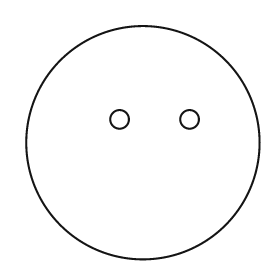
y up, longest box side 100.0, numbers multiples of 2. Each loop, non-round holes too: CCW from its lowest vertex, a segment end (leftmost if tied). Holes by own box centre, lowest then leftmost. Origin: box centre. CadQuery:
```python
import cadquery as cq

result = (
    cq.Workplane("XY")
    .moveTo(0.0, 0.0)
    .circle(50.0)
    .moveTo(-10.0, 10.0)
    .circle(4.0)
    .moveTo(20.0, 10.0)
    .circle(4.0)
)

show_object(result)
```